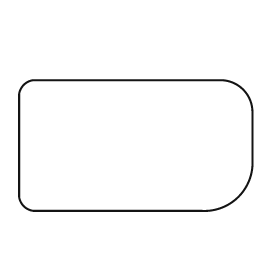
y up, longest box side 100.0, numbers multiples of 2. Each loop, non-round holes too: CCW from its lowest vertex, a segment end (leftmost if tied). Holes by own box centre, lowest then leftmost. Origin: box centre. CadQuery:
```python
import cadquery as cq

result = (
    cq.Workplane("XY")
    .moveTo(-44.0, -28.0)
    .lineTo(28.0, -28.0)
    .threePointArc((44.0, -22.0), (50.0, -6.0))
    .lineTo(50.0, 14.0)
    .threePointArc((46.0, 24.0), (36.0, 28.0))
    .lineTo(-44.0, 28.0)
    .threePointArc((-48.0, 26.0), (-50.0, 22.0))
    .lineTo(-50.0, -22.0)
    .threePointArc((-48.0, -26.0), (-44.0, -28.0))
    .close()
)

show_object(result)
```